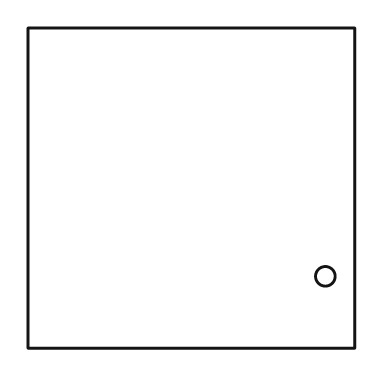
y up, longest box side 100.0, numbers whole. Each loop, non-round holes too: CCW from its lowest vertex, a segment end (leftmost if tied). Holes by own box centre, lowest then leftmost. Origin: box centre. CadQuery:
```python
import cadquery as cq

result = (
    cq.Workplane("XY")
    .moveTo(-50.0, -49.0)
    .lineTo(50.0, -49.0)
    .lineTo(50.0, 49.0)
    .lineTo(-50.0, 49.0)
    .close()
    .moveTo(41.0, -27.0)
    .circle(3.0)
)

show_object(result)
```